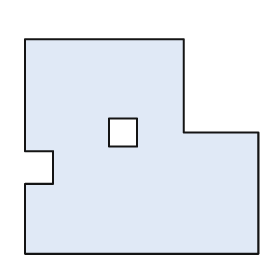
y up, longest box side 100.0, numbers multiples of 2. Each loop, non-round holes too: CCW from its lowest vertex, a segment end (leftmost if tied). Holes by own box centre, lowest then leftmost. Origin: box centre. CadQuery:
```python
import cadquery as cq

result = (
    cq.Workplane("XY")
    .moveTo(-50.0, -46.0)
    .lineTo(50.0, -46.0)
    .lineTo(50.0, 6.0)
    .lineTo(18.0, 6.0)
    .lineTo(18.0, 46.0)
    .lineTo(-50.0, 46.0)
    .lineTo(-50.0, -2.0)
    .lineTo(-38.0, -2.0)
    .lineTo(-38.0, -16.0)
    .lineTo(-50.0, -16.0)
    .close()
    .moveTo(-14.0, 0.0)
    .lineTo(-2.0, 0.0)
    .lineTo(-2.0, 12.0)
    .lineTo(-14.0, 12.0)
    .close()
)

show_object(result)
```